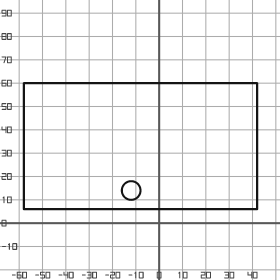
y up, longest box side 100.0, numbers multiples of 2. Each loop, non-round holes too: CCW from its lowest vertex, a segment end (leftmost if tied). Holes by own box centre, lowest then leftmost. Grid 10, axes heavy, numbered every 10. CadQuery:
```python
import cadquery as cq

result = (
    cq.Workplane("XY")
    .moveTo(-58.0, 6.0)
    .lineTo(42.0, 6.0)
    .lineTo(42.0, 60.0)
    .lineTo(-58.0, 60.0)
    .close()
    .moveTo(-12.0, 14.0)
    .circle(4.0)
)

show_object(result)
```